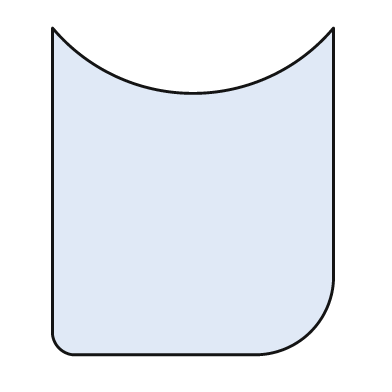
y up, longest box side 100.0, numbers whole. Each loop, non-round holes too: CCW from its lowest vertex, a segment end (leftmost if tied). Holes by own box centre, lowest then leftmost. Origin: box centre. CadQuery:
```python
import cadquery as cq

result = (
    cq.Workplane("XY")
    .moveTo(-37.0, -50.0)
    .lineTo(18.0, -50.0)
    .threePointArc((36.0, -43.0), (43.0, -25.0))
    .lineTo(43.0, 50.0)
    .threePointArc((0.0, 30.0), (-43.0, 50.0))
    .lineTo(-43.0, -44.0)
    .threePointArc((-41.0, -48.0), (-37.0, -50.0))
    .close()
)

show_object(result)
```